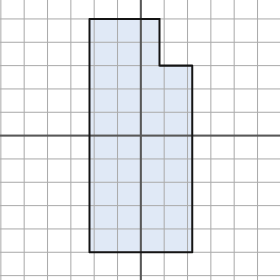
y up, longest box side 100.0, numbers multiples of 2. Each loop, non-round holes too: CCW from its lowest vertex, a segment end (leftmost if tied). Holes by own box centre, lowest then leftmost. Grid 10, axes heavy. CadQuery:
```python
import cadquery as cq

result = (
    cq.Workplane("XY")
    .moveTo(-22.0, -50.0)
    .lineTo(22.0, -50.0)
    .lineTo(22.0, 30.0)
    .lineTo(8.0, 30.0)
    .lineTo(8.0, 50.0)
    .lineTo(-22.0, 50.0)
    .close()
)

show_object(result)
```